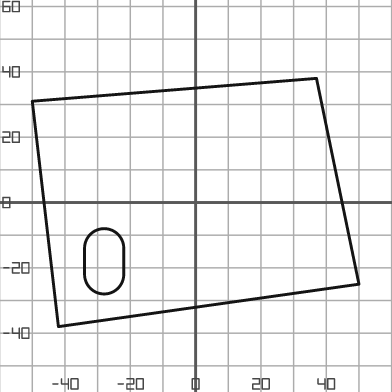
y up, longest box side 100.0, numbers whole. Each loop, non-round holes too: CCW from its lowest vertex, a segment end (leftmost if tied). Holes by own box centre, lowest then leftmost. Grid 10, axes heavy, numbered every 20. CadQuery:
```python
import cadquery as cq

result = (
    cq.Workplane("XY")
    .moveTo(-42.0, -38.0)
    .lineTo(50.0, -25.0)
    .lineTo(37.0, 38.0)
    .lineTo(-50.0, 31.0)
    .close()
    .moveTo(-34.0, -22.0)
    .threePointArc((-28.0, -28.0), (-22.0, -22.0))
    .lineTo(-22.0, -14.0)
    .threePointArc((-28.0, -8.0), (-34.0, -14.0))
    .close()
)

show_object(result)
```